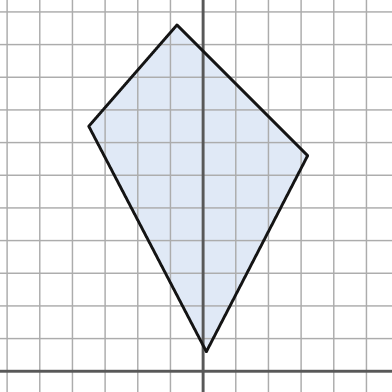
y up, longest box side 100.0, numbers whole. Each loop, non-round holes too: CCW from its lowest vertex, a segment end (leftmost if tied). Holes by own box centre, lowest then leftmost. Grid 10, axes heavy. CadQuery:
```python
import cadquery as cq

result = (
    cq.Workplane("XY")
    .moveTo(1.0, 6.0)
    .lineTo(32.0, 66.0)
    .lineTo(-8.0, 106.0)
    .lineTo(-35.0, 75.0)
    .close()
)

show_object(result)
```